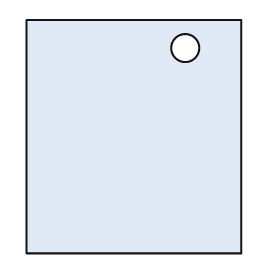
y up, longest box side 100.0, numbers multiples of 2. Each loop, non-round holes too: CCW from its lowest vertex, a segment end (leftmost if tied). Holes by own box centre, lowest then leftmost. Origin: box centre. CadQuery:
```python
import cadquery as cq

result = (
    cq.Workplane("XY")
    .moveTo(-46.0, -50.0)
    .lineTo(46.0, -50.0)
    .lineTo(46.0, 50.0)
    .lineTo(-46.0, 50.0)
    .close()
    .moveTo(22.0, 38.0)
    .circle(6.0)
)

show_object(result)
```